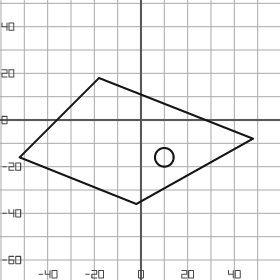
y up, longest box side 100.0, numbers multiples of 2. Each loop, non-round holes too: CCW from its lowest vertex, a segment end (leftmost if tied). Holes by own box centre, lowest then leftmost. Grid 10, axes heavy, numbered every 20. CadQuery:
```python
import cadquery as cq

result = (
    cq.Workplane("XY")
    .moveTo(-2.0, -36.0)
    .lineTo(48.0, -8.0)
    .lineTo(-18.0, 18.0)
    .lineTo(-52.0, -16.0)
    .close()
    .moveTo(10.0, -16.0)
    .circle(4.0)
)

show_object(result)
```